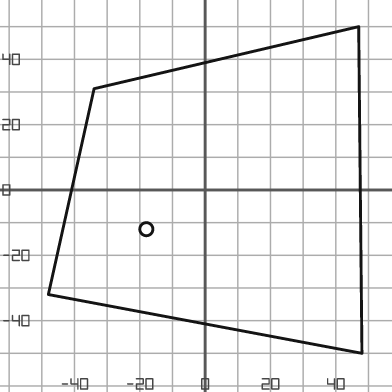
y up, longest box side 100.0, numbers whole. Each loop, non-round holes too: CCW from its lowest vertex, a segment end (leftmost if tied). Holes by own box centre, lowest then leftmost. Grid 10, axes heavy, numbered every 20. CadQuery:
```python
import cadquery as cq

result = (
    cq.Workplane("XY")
    .moveTo(48.0, -50.0)
    .lineTo(47.0, 50.0)
    .lineTo(-34.0, 31.0)
    .lineTo(-48.0, -32.0)
    .close()
    .moveTo(-18.0, -12.0)
    .circle(2.0)
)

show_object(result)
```